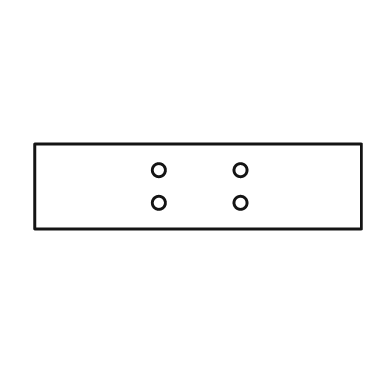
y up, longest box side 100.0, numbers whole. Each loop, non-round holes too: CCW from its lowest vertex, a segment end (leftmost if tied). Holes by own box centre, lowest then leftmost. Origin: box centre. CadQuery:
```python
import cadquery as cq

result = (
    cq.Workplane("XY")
    .moveTo(-50.0, -13.0)
    .lineTo(50.0, -13.0)
    .lineTo(50.0, 13.0)
    .lineTo(-50.0, 13.0)
    .close()
    .moveTo(-12.0, -5.0)
    .circle(2.0)
    .moveTo(13.0, -5.0)
    .circle(2.0)
    .moveTo(-12.0, 5.0)
    .circle(2.0)
    .moveTo(13.0, 5.0)
    .circle(2.0)
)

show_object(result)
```